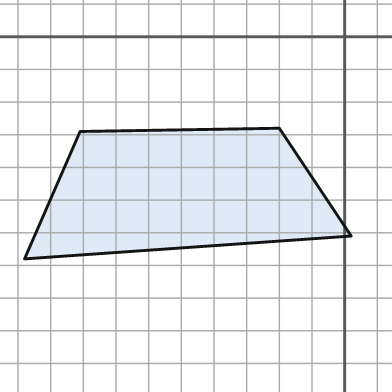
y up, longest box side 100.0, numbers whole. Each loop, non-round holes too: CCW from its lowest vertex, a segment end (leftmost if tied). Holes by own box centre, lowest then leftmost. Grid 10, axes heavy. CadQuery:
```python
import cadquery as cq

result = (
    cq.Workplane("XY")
    .moveTo(-98.0, -68.0)
    .lineTo(2.0, -61.0)
    .lineTo(-20.0, -28.0)
    .lineTo(-81.0, -29.0)
    .close()
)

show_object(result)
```